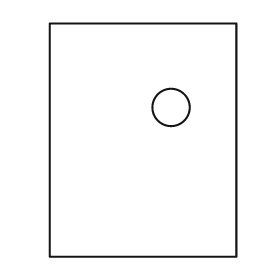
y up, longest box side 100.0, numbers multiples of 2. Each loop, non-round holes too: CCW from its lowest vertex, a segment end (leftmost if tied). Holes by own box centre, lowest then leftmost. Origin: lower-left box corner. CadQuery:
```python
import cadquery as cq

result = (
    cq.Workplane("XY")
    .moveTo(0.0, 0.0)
    .lineTo(80.0, 0.0)
    .lineTo(80.0, 100.0)
    .lineTo(0.0, 100.0)
    .close()
    .moveTo(52.0, 64.0)
    .circle(8.0)
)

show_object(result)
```